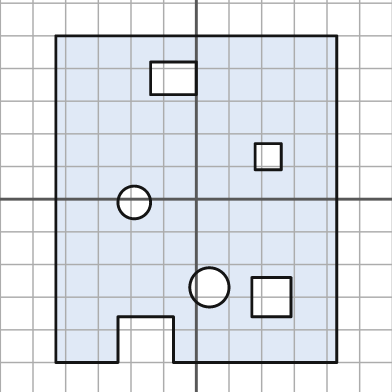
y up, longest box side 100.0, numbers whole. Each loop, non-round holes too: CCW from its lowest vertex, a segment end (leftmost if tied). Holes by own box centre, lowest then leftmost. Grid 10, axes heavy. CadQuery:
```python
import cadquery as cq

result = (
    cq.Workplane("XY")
    .moveTo(-43.0, -50.0)
    .lineTo(-24.0, -50.0)
    .lineTo(-24.0, -36.0)
    .lineTo(-7.0, -36.0)
    .lineTo(-7.0, -50.0)
    .lineTo(43.0, -50.0)
    .lineTo(43.0, 50.0)
    .lineTo(-43.0, 50.0)
    .close()
    .moveTo(17.0, -36.0)
    .lineTo(29.0, -36.0)
    .lineTo(29.0, -24.0)
    .lineTo(17.0, -24.0)
    .close()
    .moveTo(4.0, -27.0)
    .circle(6.0)
    .moveTo(-19.0, -1.0)
    .circle(5.0)
    .moveTo(18.0, 9.0)
    .lineTo(26.0, 9.0)
    .lineTo(26.0, 17.0)
    .lineTo(18.0, 17.0)
    .close()
    .moveTo(-14.0, 32.0)
    .lineTo(0.0, 32.0)
    .lineTo(0.0, 42.0)
    .lineTo(-14.0, 42.0)
    .close()
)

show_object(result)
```